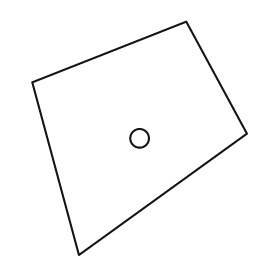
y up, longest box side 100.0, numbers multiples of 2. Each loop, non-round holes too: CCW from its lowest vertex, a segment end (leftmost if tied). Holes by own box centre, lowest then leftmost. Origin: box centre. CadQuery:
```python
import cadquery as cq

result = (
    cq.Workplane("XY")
    .moveTo(-26.0, -50.0)
    .lineTo(46.0, 2.0)
    .lineTo(20.0, 50.0)
    .lineTo(-46.0, 24.0)
    .close()
    .moveTo(0.0, 0.0)
    .circle(4.0)
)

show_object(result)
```